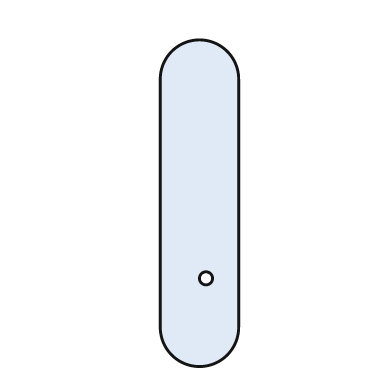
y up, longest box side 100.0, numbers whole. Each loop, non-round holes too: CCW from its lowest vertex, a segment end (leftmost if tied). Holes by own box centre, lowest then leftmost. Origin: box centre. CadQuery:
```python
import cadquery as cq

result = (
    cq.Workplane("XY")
    .moveTo(-12.0, -38.0)
    .threePointArc((0.0, -50.0), (12.0, -38.0))
    .lineTo(12.0, 38.0)
    .threePointArc((0.0, 50.0), (-12.0, 38.0))
    .close()
    .moveTo(2.0, -23.0)
    .circle(2.0)
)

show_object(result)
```